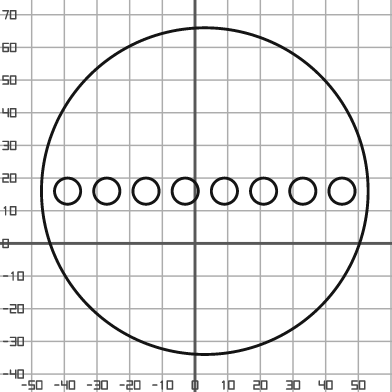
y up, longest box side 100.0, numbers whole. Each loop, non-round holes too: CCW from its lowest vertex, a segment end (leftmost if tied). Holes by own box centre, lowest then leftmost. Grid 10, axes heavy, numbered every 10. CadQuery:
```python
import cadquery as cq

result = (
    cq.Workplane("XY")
    .moveTo(3.0, 16.0)
    .circle(50.0)
    .moveTo(-39.0, 16.0)
    .circle(4.0)
    .moveTo(-27.0, 16.0)
    .circle(4.0)
    .moveTo(-15.0, 16.0)
    .circle(4.0)
    .moveTo(-3.0, 16.0)
    .circle(4.0)
    .moveTo(9.0, 16.0)
    .circle(4.0)
    .moveTo(21.0, 16.0)
    .circle(4.0)
    .moveTo(33.0, 16.0)
    .circle(4.0)
    .moveTo(45.0, 16.0)
    .circle(4.0)
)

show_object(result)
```